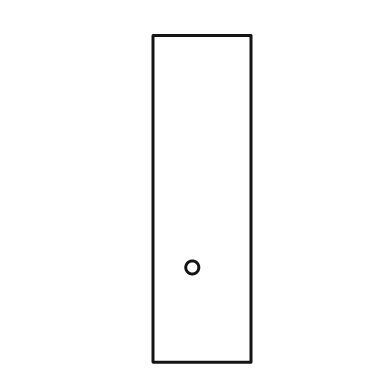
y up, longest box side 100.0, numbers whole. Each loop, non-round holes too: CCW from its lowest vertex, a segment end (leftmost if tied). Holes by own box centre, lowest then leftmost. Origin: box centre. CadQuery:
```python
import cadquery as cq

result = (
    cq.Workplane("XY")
    .moveTo(-15.0, -50.0)
    .lineTo(15.0, -50.0)
    .lineTo(15.0, 50.0)
    .lineTo(-15.0, 50.0)
    .close()
    .moveTo(-3.0, -21.0)
    .circle(2.0)
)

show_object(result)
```